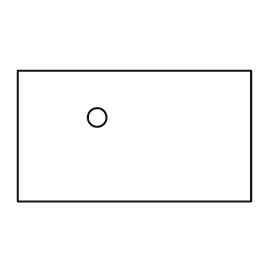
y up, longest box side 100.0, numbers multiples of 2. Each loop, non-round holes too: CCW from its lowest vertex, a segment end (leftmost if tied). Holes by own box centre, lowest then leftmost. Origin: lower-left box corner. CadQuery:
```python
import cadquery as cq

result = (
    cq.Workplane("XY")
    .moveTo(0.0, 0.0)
    .lineTo(100.0, 0.0)
    .lineTo(100.0, 56.0)
    .lineTo(0.0, 56.0)
    .close()
    .moveTo(34.0, 36.0)
    .circle(4.0)
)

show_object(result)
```